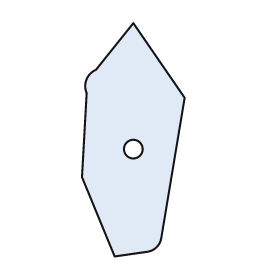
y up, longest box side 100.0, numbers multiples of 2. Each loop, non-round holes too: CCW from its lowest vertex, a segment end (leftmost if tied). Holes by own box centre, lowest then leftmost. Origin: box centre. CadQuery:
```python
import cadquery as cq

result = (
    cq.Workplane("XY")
    .moveTo(-8.0, -50.0)
    .lineTo(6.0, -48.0)
    .threePointArc((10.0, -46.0), (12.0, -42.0))
    .lineTo(22.0, 18.0)
    .lineTo(0.0, 50.0)
    .lineTo(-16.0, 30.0)
    .threePointArc((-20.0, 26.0), (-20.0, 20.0))
    .lineTo(-22.0, -16.0)
    .close()
    .moveTo(0.0, -4.0)
    .circle(4.0)
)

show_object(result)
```